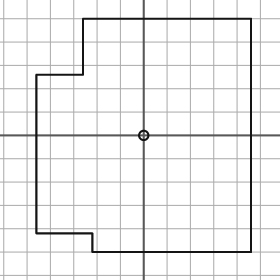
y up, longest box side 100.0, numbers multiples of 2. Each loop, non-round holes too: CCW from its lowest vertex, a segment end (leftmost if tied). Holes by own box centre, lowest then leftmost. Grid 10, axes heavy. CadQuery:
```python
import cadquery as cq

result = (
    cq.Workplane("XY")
    .moveTo(-22.0, -50.0)
    .lineTo(46.0, -50.0)
    .lineTo(46.0, 50.0)
    .lineTo(-26.0, 50.0)
    .lineTo(-26.0, 26.0)
    .lineTo(-46.0, 26.0)
    .lineTo(-46.0, -42.0)
    .lineTo(-22.0, -42.0)
    .close()
    .moveTo(0.0, 0.0)
    .circle(2.0)
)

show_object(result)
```